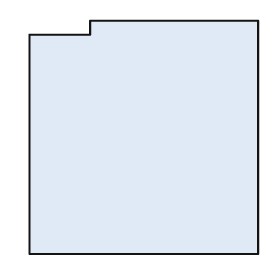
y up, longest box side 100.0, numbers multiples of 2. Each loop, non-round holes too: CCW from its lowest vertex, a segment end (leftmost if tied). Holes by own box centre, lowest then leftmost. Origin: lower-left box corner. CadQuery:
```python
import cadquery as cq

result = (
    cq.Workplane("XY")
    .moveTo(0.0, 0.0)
    .lineTo(98.0, 0.0)
    .lineTo(98.0, 100.0)
    .lineTo(26.0, 100.0)
    .lineTo(26.0, 94.0)
    .lineTo(0.0, 94.0)
    .close()
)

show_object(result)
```